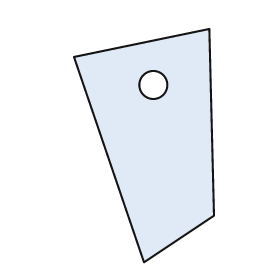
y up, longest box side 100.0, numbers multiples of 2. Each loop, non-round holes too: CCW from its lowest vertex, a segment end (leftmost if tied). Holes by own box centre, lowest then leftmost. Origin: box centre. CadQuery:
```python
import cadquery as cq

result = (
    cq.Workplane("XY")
    .moveTo(0.0, -50.0)
    .lineTo(30.0, -30.0)
    .lineTo(28.0, 50.0)
    .lineTo(-30.0, 38.0)
    .close()
    .moveTo(4.0, 26.0)
    .circle(6.0)
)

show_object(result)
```